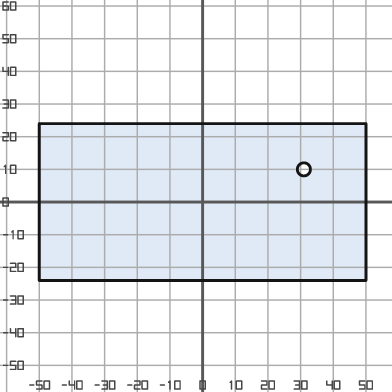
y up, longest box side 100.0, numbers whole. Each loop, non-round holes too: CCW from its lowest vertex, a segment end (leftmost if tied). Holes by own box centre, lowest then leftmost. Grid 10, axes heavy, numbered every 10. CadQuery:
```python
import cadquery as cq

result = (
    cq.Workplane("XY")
    .moveTo(-50.0, -24.0)
    .lineTo(50.0, -24.0)
    .lineTo(50.0, 24.0)
    .lineTo(-50.0, 24.0)
    .close()
    .moveTo(31.0, 10.0)
    .circle(2.0)
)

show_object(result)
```